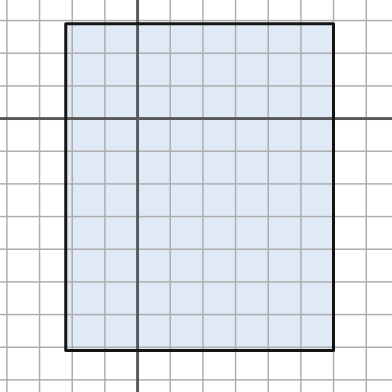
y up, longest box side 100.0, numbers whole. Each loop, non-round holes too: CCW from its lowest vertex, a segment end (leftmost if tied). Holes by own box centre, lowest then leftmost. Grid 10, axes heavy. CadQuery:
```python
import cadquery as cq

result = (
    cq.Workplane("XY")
    .moveTo(-22.0, -71.0)
    .lineTo(60.0, -71.0)
    .lineTo(60.0, 29.0)
    .lineTo(-22.0, 29.0)
    .close()
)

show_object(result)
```